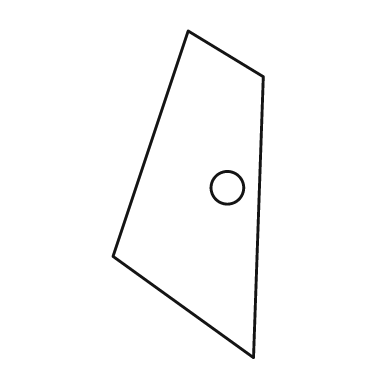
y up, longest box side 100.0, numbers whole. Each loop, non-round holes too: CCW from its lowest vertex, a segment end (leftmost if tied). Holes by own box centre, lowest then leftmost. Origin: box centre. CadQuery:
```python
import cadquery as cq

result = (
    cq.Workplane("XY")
    .moveTo(20.0, -50.0)
    .lineTo(23.0, 36.0)
    .lineTo(0.0, 50.0)
    .lineTo(-23.0, -19.0)
    .close()
    .moveTo(12.0, 2.0)
    .circle(5.0)
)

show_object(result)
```